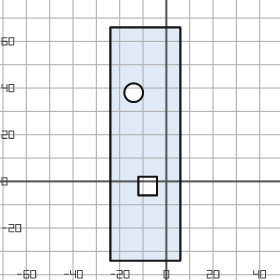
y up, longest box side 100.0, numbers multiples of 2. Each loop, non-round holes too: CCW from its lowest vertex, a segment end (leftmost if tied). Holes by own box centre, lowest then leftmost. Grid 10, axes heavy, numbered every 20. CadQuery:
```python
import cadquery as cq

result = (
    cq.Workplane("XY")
    .moveTo(-24.0, -34.0)
    .lineTo(6.0, -34.0)
    .lineTo(6.0, 66.0)
    .lineTo(-24.0, 66.0)
    .close()
    .moveTo(-12.0, -6.0)
    .lineTo(-4.0, -6.0)
    .lineTo(-4.0, 2.0)
    .lineTo(-12.0, 2.0)
    .close()
    .moveTo(-14.0, 38.0)
    .circle(4.0)
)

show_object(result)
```